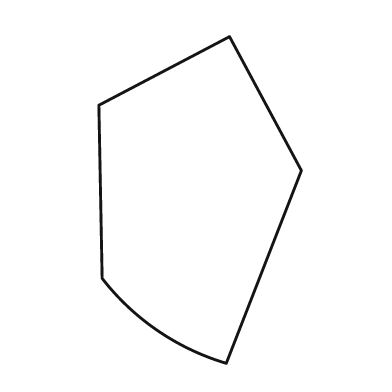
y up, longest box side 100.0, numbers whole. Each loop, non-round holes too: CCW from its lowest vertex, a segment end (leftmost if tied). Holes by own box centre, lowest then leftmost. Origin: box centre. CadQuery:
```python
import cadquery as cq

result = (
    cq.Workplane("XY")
    .moveTo(8.0, -50.0)
    .lineTo(31.0, 9.0)
    .lineTo(9.0, 50.0)
    .lineTo(-31.0, 29.0)
    .lineTo(-30.0, -24.0)
    .threePointArc((-13.0, -40.0), (8.0, -50.0))
    .close()
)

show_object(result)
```